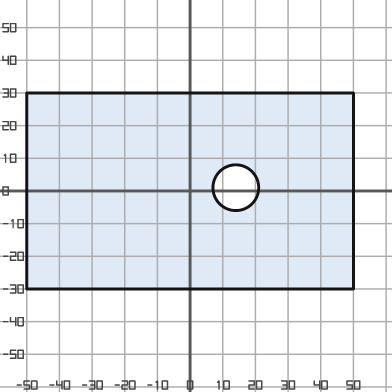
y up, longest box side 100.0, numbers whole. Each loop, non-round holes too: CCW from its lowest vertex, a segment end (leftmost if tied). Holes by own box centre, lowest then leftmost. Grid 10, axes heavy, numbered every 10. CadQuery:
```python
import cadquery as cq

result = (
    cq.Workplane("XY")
    .moveTo(-50.0, -30.0)
    .lineTo(50.0, -30.0)
    .lineTo(50.0, 30.0)
    .lineTo(-50.0, 30.0)
    .close()
    .moveTo(14.0, 1.0)
    .circle(7.0)
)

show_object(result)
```